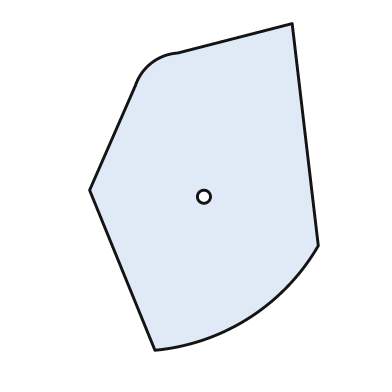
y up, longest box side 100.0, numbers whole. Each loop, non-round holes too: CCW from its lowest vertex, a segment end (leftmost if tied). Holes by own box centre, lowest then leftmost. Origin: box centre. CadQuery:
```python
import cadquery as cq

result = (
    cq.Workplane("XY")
    .moveTo(-15.0, -50.0)
    .threePointArc((14.0, -40.0), (35.0, -18.0))
    .lineTo(27.0, 50.0)
    .lineTo(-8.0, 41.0)
    .threePointArc((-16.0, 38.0), (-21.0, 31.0))
    .lineTo(-35.0, -1.0)
    .close()
    .moveTo(0.0, -3.0)
    .circle(2.0)
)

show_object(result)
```